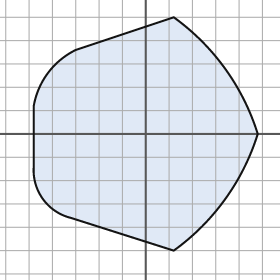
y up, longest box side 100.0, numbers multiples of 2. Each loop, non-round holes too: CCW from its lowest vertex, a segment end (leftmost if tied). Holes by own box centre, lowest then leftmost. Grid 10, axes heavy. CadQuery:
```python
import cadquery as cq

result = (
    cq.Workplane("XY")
    .moveTo(12.0, -50.0)
    .threePointArc((34.0, -28.0), (48.0, 0.0))
    .threePointArc((34.0, 28.0), (12.0, 50.0))
    .lineTo(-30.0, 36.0)
    .threePointArc((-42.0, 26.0), (-48.0, 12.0))
    .lineTo(-48.0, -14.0)
    .threePointArc((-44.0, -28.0), (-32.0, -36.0))
    .close()
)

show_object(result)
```